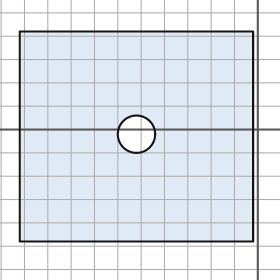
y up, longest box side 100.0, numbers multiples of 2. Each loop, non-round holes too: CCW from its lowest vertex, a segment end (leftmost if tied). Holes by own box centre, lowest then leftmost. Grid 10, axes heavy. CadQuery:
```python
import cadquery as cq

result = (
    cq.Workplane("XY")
    .moveTo(-102.0, -48.0)
    .lineTo(-2.0, -48.0)
    .lineTo(-2.0, 42.0)
    .lineTo(-102.0, 42.0)
    .close()
    .moveTo(-52.0, -2.0)
    .circle(8.0)
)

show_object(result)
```